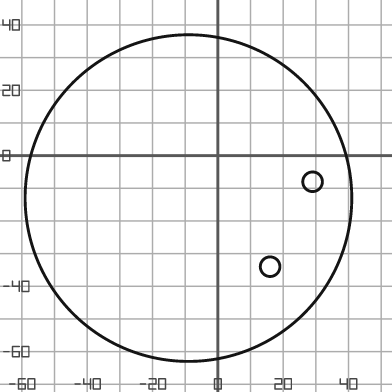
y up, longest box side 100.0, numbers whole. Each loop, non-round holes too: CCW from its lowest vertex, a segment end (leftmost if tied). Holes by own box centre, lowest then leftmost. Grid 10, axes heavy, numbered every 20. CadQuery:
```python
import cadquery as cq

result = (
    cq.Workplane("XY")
    .moveTo(-9.0, -13.0)
    .circle(50.0)
    .moveTo(16.0, -34.0)
    .circle(3.0)
    .moveTo(29.0, -8.0)
    .circle(3.0)
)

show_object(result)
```